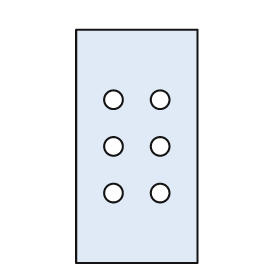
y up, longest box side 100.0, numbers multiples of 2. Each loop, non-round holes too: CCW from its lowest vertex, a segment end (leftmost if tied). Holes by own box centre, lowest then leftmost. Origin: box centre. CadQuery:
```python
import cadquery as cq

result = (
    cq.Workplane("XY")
    .moveTo(-26.0, -50.0)
    .lineTo(26.0, -50.0)
    .lineTo(26.0, 50.0)
    .lineTo(-26.0, 50.0)
    .close()
    .moveTo(-10.0, -20.0)
    .circle(4.0)
    .moveTo(10.0, -20.0)
    .circle(4.0)
    .moveTo(-10.0, 0.0)
    .circle(4.0)
    .moveTo(10.0, 0.0)
    .circle(4.0)
    .moveTo(-10.0, 20.0)
    .circle(4.0)
    .moveTo(10.0, 20.0)
    .circle(4.0)
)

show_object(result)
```